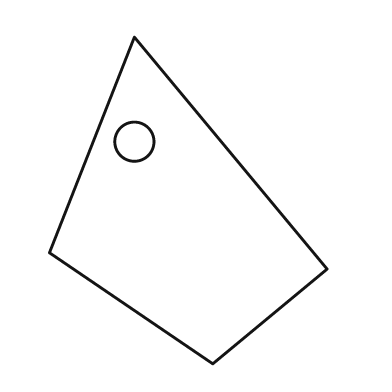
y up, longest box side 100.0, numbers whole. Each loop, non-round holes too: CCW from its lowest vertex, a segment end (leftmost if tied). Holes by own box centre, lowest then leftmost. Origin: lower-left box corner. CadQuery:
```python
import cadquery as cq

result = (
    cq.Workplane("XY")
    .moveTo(50.0, 0.0)
    .lineTo(85.0, 29.0)
    .lineTo(26.0, 100.0)
    .lineTo(0.0, 34.0)
    .close()
    .moveTo(26.0, 68.0)
    .circle(6.0)
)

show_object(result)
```